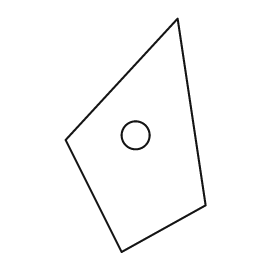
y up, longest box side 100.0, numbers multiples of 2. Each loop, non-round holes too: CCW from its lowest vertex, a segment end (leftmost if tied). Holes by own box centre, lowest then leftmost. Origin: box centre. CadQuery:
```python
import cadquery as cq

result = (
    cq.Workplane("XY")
    .moveTo(-6.0, -50.0)
    .lineTo(30.0, -30.0)
    .lineTo(18.0, 50.0)
    .lineTo(-30.0, -2.0)
    .close()
    .moveTo(0.0, 0.0)
    .circle(6.0)
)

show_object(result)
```